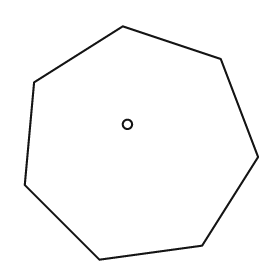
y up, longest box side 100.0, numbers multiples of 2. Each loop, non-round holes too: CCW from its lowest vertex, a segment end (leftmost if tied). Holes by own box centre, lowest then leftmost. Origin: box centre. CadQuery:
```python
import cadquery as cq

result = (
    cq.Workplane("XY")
    .moveTo(-18.0, -50.0)
    .lineTo(26.0, -44.0)
    .lineTo(50.0, -6.0)
    .lineTo(34.0, 36.0)
    .lineTo(-8.0, 50.0)
    .lineTo(-46.0, 26.0)
    .lineTo(-50.0, -18.0)
    .close()
    .moveTo(-6.0, 8.0)
    .circle(2.0)
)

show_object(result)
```